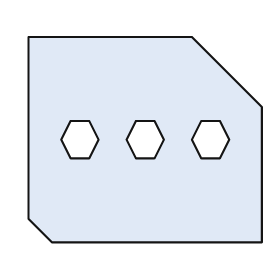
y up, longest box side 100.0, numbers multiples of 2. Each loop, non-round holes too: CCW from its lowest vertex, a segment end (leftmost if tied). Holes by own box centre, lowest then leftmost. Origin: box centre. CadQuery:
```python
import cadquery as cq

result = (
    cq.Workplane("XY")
    .moveTo(-40.0, -44.0)
    .lineTo(50.0, -44.0)
    .lineTo(50.0, 14.0)
    .lineTo(20.0, 44.0)
    .lineTo(-50.0, 44.0)
    .lineTo(-50.0, -34.0)
    .close()
    .moveTo(-32.0, -8.0)
    .lineTo(-24.0, -8.0)
    .lineTo(-20.0, 0.0)
    .lineTo(-24.0, 8.0)
    .lineTo(-32.0, 8.0)
    .lineTo(-36.0, 0.0)
    .close()
    .moveTo(-4.0, -8.0)
    .lineTo(4.0, -8.0)
    .lineTo(8.0, 0.0)
    .lineTo(4.0, 8.0)
    .lineTo(-4.0, 8.0)
    .lineTo(-8.0, 0.0)
    .close()
    .moveTo(24.0, -8.0)
    .lineTo(32.0, -8.0)
    .lineTo(36.0, 0.0)
    .lineTo(32.0, 8.0)
    .lineTo(24.0, 8.0)
    .lineTo(20.0, 0.0)
    .close()
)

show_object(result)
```